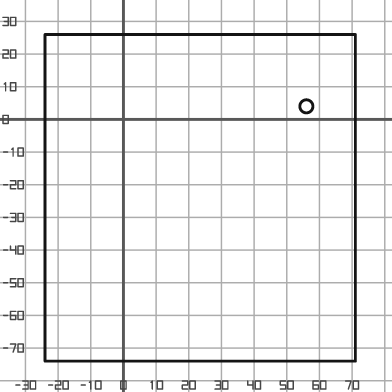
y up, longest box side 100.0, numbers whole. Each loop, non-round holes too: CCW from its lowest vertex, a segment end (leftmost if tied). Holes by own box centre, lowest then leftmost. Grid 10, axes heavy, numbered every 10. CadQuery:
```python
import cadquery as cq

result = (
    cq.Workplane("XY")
    .moveTo(-24.0, -74.0)
    .lineTo(71.0, -74.0)
    .lineTo(71.0, 26.0)
    .lineTo(-24.0, 26.0)
    .close()
    .moveTo(56.0, 4.0)
    .circle(2.0)
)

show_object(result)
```